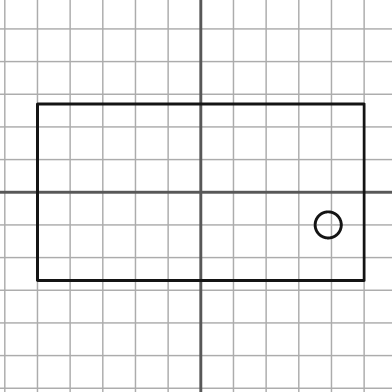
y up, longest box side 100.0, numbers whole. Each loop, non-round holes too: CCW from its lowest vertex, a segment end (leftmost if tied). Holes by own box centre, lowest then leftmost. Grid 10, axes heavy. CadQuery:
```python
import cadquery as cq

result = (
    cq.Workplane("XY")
    .moveTo(-50.0, -27.0)
    .lineTo(50.0, -27.0)
    .lineTo(50.0, 27.0)
    .lineTo(-50.0, 27.0)
    .close()
    .moveTo(39.0, -10.0)
    .circle(4.0)
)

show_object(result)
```